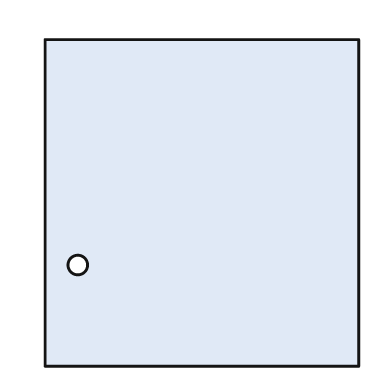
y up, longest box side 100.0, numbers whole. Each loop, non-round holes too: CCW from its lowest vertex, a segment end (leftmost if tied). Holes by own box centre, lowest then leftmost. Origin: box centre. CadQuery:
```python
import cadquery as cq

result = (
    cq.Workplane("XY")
    .moveTo(-48.0, -50.0)
    .lineTo(48.0, -50.0)
    .lineTo(48.0, 50.0)
    .lineTo(-48.0, 50.0)
    .close()
    .moveTo(-38.0, -19.0)
    .circle(3.0)
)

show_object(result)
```